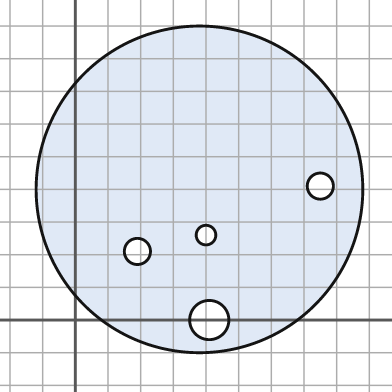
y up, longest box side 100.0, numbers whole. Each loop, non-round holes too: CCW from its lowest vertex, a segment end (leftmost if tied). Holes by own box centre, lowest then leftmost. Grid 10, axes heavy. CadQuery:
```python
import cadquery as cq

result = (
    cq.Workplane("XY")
    .moveTo(38.0, 40.0)
    .circle(50.0)
    .moveTo(41.0, 0.0)
    .circle(6.0)
    .moveTo(19.0, 21.0)
    .circle(4.0)
    .moveTo(40.0, 26.0)
    .circle(3.0)
    .moveTo(75.0, 41.0)
    .circle(4.0)
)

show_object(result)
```